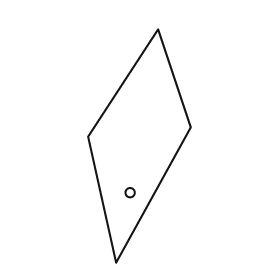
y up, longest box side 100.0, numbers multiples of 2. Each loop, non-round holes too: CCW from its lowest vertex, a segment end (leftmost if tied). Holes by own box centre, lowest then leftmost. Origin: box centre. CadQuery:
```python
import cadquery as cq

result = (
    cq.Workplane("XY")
    .moveTo(-10.0, -50.0)
    .lineTo(22.0, 8.0)
    .lineTo(8.0, 50.0)
    .lineTo(-22.0, 4.0)
    .close()
    .moveTo(-4.0, -20.0)
    .circle(2.0)
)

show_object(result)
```